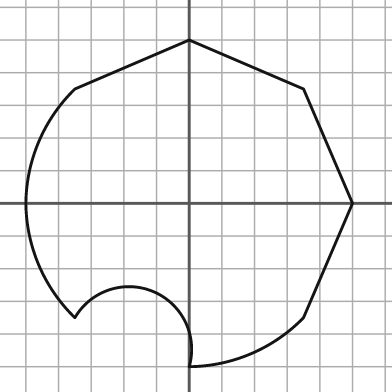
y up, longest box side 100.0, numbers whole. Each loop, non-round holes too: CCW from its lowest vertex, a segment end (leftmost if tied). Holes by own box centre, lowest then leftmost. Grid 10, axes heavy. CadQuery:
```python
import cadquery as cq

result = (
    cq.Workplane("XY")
    .moveTo(0.0, -50.0)
    .threePointArc((19.0, -46.0), (35.0, -35.0))
    .lineTo(50.0, 0.0)
    .lineTo(35.0, 35.0)
    .lineTo(0.0, 50.0)
    .lineTo(-35.0, 35.0)
    .threePointArc((-46.0, 19.0), (-50.0, 0.0))
    .threePointArc((-46.0, -19.0), (-35.0, -35.0))
    .threePointArc((-11.0, -27.0), (0.0, -50.0))
    .close()
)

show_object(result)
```